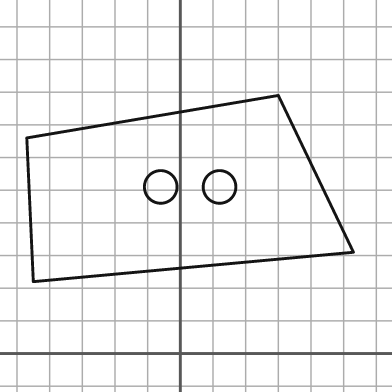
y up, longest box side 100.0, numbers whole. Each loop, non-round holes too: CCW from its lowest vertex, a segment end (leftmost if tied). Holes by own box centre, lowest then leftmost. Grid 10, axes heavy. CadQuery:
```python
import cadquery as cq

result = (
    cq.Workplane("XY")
    .moveTo(-45.0, 22.0)
    .lineTo(53.0, 31.0)
    .lineTo(30.0, 79.0)
    .lineTo(-47.0, 66.0)
    .close()
    .moveTo(-6.0, 51.0)
    .circle(5.0)
    .moveTo(12.0, 51.0)
    .circle(5.0)
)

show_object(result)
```